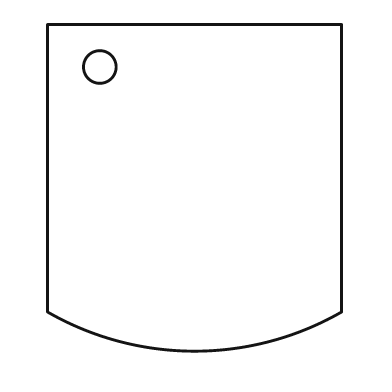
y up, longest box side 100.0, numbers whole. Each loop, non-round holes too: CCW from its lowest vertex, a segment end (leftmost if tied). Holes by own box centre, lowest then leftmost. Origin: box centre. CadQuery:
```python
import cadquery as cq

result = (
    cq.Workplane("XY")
    .moveTo(-45.0, -38.0)
    .threePointArc((0.0, -50.0), (45.0, -38.0))
    .lineTo(45.0, 50.0)
    .lineTo(-45.0, 50.0)
    .close()
    .moveTo(-29.0, 37.0)
    .circle(5.0)
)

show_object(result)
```